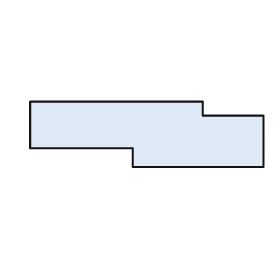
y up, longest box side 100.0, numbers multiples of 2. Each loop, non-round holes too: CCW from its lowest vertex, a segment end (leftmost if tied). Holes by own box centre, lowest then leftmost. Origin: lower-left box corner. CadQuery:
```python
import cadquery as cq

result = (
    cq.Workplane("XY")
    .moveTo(44.0, 0.0)
    .lineTo(100.0, 0.0)
    .lineTo(100.0, 22.0)
    .lineTo(74.0, 22.0)
    .lineTo(74.0, 28.0)
    .lineTo(0.0, 28.0)
    .lineTo(0.0, 8.0)
    .lineTo(44.0, 8.0)
    .close()
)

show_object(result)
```